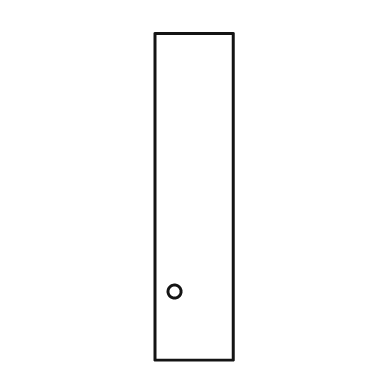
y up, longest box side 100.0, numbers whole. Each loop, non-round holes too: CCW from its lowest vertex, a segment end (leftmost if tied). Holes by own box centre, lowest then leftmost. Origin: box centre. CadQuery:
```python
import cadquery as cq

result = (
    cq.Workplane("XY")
    .moveTo(-12.0, -50.0)
    .lineTo(12.0, -50.0)
    .lineTo(12.0, 50.0)
    .lineTo(-12.0, 50.0)
    .close()
    .moveTo(-6.0, -29.0)
    .circle(2.0)
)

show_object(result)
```